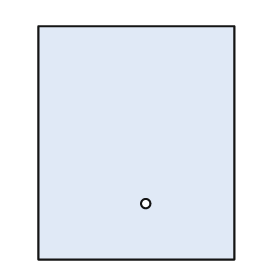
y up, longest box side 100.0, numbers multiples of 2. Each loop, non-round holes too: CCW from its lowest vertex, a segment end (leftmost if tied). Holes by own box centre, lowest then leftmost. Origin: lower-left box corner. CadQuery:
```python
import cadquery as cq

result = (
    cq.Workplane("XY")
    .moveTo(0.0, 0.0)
    .lineTo(84.0, 0.0)
    .lineTo(84.0, 100.0)
    .lineTo(0.0, 100.0)
    .close()
    .moveTo(46.0, 24.0)
    .circle(2.0)
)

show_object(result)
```